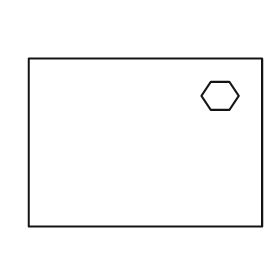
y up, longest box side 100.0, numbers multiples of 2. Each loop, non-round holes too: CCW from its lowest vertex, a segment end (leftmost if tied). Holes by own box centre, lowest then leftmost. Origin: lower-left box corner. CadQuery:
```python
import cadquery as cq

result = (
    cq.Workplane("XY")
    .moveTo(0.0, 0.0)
    .lineTo(100.0, 0.0)
    .lineTo(100.0, 72.0)
    .lineTo(0.0, 72.0)
    .close()
    .moveTo(78.0, 50.0)
    .lineTo(86.0, 50.0)
    .lineTo(90.0, 56.0)
    .lineTo(86.0, 62.0)
    .lineTo(78.0, 62.0)
    .lineTo(74.0, 56.0)
    .close()
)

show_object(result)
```